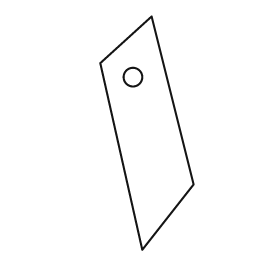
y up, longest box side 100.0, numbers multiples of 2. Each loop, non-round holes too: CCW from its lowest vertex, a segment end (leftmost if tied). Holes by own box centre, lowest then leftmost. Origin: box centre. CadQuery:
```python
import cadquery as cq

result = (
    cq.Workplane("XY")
    .moveTo(-2.0, -50.0)
    .lineTo(20.0, -22.0)
    .lineTo(2.0, 50.0)
    .lineTo(-20.0, 30.0)
    .close()
    .moveTo(-6.0, 24.0)
    .circle(4.0)
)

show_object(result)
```